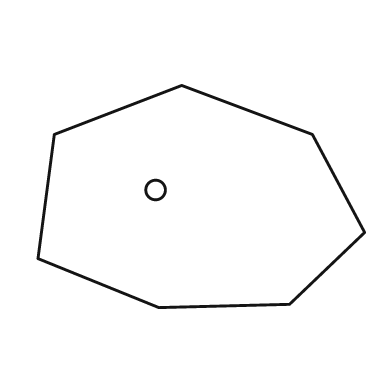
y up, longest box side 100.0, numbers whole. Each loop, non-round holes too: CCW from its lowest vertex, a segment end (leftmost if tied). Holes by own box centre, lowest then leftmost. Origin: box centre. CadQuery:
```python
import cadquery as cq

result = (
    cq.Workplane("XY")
    .moveTo(-13.0, -34.0)
    .lineTo(27.0, -33.0)
    .lineTo(50.0, -11.0)
    .lineTo(34.0, 19.0)
    .lineTo(-6.0, 34.0)
    .lineTo(-45.0, 19.0)
    .lineTo(-50.0, -19.0)
    .close()
    .moveTo(-14.0, 2.0)
    .circle(3.0)
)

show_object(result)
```